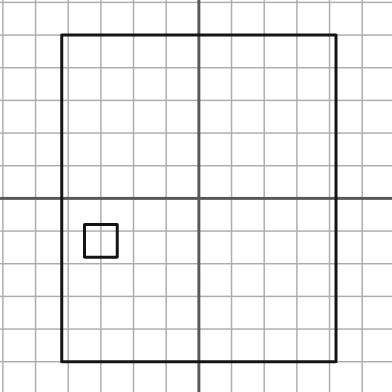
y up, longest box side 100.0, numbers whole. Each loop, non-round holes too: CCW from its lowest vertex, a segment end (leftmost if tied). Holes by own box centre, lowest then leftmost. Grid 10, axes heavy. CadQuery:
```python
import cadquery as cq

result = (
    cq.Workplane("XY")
    .moveTo(-42.0, -50.0)
    .lineTo(42.0, -50.0)
    .lineTo(42.0, 50.0)
    .lineTo(-42.0, 50.0)
    .close()
    .moveTo(-35.0, -18.0)
    .lineTo(-25.0, -18.0)
    .lineTo(-25.0, -8.0)
    .lineTo(-35.0, -8.0)
    .close()
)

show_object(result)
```